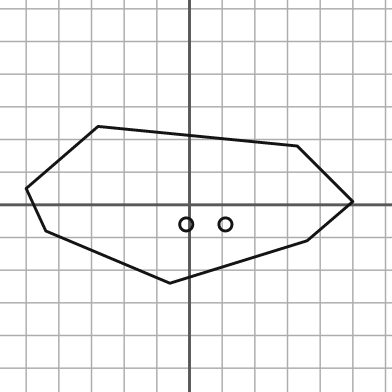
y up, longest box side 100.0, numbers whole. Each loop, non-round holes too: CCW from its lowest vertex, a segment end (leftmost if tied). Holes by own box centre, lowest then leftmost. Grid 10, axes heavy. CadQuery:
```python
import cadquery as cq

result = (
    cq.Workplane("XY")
    .moveTo(-6.0, -24.0)
    .lineTo(36.0, -11.0)
    .lineTo(50.0, 1.0)
    .lineTo(33.0, 18.0)
    .lineTo(-28.0, 24.0)
    .lineTo(-50.0, 5.0)
    .lineTo(-44.0, -8.0)
    .close()
    .moveTo(-1.0, -6.0)
    .circle(2.0)
    .moveTo(11.0, -6.0)
    .circle(2.0)
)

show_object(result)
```